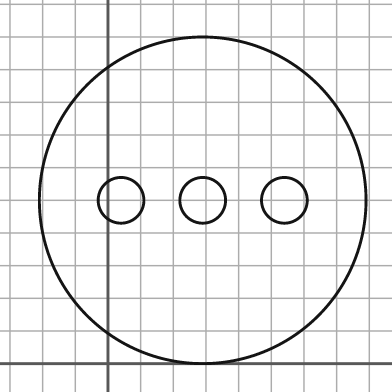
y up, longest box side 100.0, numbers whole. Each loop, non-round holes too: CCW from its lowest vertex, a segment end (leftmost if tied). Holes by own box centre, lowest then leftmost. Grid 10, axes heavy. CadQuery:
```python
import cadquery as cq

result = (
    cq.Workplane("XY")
    .moveTo(29.0, 50.0)
    .circle(50.0)
    .moveTo(4.0, 50.0)
    .circle(7.0)
    .moveTo(29.0, 50.0)
    .circle(7.0)
    .moveTo(54.0, 50.0)
    .circle(7.0)
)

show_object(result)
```